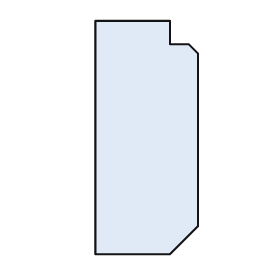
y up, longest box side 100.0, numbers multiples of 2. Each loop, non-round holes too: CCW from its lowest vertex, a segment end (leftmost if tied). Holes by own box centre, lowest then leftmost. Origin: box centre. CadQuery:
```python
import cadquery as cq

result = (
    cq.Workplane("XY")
    .moveTo(-22.0, -50.0)
    .lineTo(10.0, -50.0)
    .lineTo(22.0, -38.0)
    .lineTo(22.0, 36.0)
    .lineTo(18.0, 40.0)
    .lineTo(10.0, 40.0)
    .lineTo(10.0, 50.0)
    .lineTo(-22.0, 50.0)
    .close()
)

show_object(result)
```